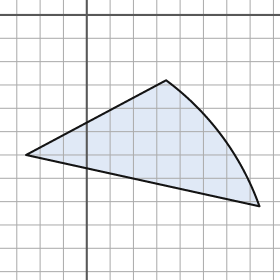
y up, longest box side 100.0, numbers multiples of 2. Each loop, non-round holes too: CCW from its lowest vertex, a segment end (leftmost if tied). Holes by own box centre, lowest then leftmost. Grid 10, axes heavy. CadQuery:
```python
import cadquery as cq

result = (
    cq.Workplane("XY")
    .moveTo(74.0, -82.0)
    .threePointArc((58.0, -52.0), (34.0, -28.0))
    .lineTo(-26.0, -60.0)
    .close()
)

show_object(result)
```